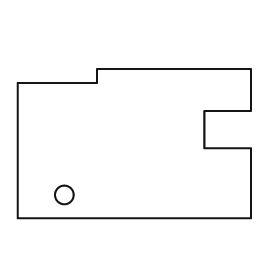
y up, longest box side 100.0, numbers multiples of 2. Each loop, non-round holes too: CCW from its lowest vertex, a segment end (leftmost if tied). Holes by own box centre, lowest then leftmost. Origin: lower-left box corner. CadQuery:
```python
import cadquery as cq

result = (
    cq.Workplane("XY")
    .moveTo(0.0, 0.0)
    .lineTo(100.0, 0.0)
    .lineTo(100.0, 30.0)
    .lineTo(80.0, 30.0)
    .lineTo(80.0, 46.0)
    .lineTo(100.0, 46.0)
    .lineTo(100.0, 64.0)
    .lineTo(34.0, 64.0)
    .lineTo(34.0, 58.0)
    .lineTo(0.0, 58.0)
    .close()
    .moveTo(20.0, 10.0)
    .circle(4.0)
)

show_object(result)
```